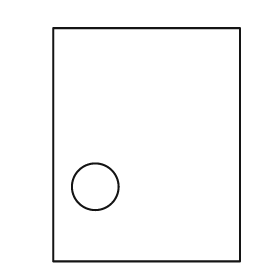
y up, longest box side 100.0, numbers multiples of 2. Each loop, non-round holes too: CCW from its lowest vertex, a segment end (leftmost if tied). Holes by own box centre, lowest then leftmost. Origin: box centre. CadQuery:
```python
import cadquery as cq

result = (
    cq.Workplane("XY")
    .moveTo(-40.0, -50.0)
    .lineTo(40.0, -50.0)
    .lineTo(40.0, 50.0)
    .lineTo(-40.0, 50.0)
    .close()
    .moveTo(-22.0, -18.0)
    .circle(10.0)
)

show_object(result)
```